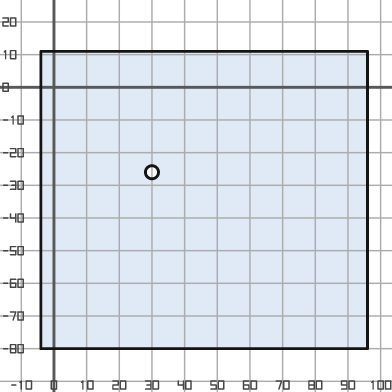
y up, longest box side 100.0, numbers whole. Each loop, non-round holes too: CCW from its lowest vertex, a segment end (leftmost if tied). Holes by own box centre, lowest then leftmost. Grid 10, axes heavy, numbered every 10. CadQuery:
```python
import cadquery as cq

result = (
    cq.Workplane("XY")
    .moveTo(-4.0, -80.0)
    .lineTo(96.0, -80.0)
    .lineTo(96.0, 11.0)
    .lineTo(-4.0, 11.0)
    .close()
    .moveTo(30.0, -26.0)
    .circle(2.0)
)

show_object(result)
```